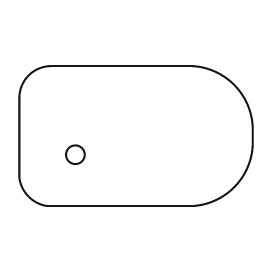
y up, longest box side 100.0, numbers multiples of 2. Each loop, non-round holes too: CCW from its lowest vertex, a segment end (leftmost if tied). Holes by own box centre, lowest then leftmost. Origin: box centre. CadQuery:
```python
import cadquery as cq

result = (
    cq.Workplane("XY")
    .moveTo(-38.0, -30.0)
    .lineTo(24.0, -30.0)
    .threePointArc((42.0, -22.0), (50.0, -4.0))
    .lineTo(50.0, 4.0)
    .threePointArc((42.0, 22.0), (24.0, 30.0))
    .lineTo(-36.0, 30.0)
    .threePointArc((-46.0, 26.0), (-50.0, 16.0))
    .lineTo(-50.0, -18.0)
    .threePointArc((-46.0, -26.0), (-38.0, -30.0))
    .close()
    .moveTo(-26.0, -8.0)
    .circle(4.0)
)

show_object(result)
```